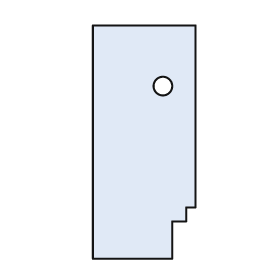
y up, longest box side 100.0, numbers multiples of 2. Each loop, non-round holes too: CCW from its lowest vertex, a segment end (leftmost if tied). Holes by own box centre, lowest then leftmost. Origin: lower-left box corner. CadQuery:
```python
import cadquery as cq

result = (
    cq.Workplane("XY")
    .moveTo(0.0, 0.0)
    .lineTo(34.0, 0.0)
    .lineTo(34.0, 16.0)
    .lineTo(40.0, 16.0)
    .lineTo(40.0, 22.0)
    .lineTo(44.0, 22.0)
    .lineTo(44.0, 100.0)
    .lineTo(0.0, 100.0)
    .close()
    .moveTo(30.0, 74.0)
    .circle(4.0)
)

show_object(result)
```